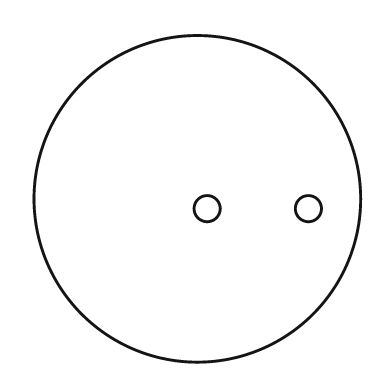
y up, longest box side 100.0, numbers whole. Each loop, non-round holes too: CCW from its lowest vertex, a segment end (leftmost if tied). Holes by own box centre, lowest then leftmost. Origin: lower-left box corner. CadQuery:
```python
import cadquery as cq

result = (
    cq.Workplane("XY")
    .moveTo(50.0, 50.0)
    .circle(50.0)
    .moveTo(53.0, 47.0)
    .circle(4.0)
    .moveTo(84.0, 47.0)
    .circle(4.0)
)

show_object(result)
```